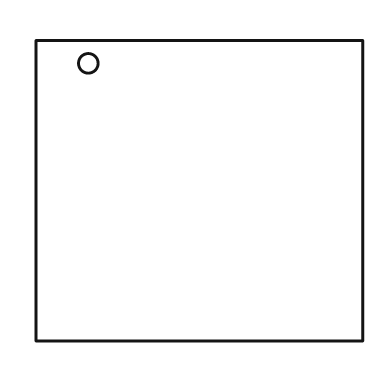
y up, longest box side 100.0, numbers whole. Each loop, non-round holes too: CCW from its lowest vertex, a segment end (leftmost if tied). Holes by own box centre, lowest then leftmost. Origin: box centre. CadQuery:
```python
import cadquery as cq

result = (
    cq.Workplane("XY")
    .moveTo(-50.0, -46.0)
    .lineTo(50.0, -46.0)
    .lineTo(50.0, 46.0)
    .lineTo(-50.0, 46.0)
    .close()
    .moveTo(-34.0, 39.0)
    .circle(3.0)
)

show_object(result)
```